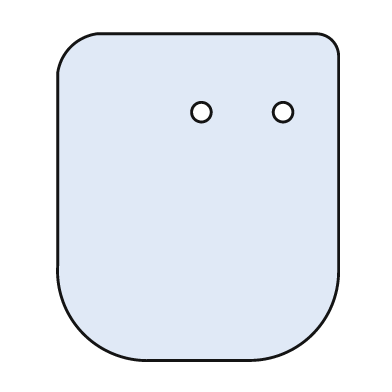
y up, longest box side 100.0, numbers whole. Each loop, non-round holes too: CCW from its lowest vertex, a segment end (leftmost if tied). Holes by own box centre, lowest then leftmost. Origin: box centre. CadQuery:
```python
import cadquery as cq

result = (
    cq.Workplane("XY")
    .moveTo(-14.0, -50.0)
    .lineTo(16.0, -50.0)
    .threePointArc((35.0, -42.0), (43.0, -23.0))
    .lineTo(43.0, 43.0)
    .threePointArc((41.0, 48.0), (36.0, 50.0))
    .lineTo(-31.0, 50.0)
    .threePointArc((-39.0, 46.0), (-43.0, 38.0))
    .lineTo(-43.0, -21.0)
    .threePointArc((-35.0, -42.0), (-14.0, -50.0))
    .close()
    .moveTo(1.0, 26.0)
    .circle(3.0)
    .moveTo(26.0, 26.0)
    .circle(3.0)
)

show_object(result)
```